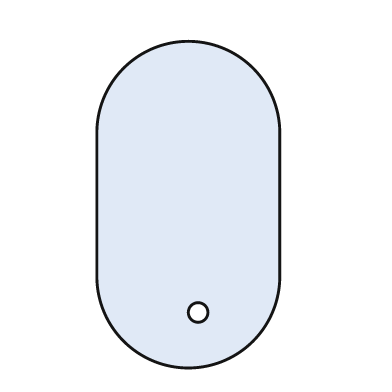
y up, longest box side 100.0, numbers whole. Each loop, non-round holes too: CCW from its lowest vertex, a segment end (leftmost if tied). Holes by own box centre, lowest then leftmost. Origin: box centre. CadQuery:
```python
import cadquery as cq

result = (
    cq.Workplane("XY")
    .moveTo(-28.0, -22.0)
    .threePointArc((0.0, -50.0), (28.0, -22.0))
    .lineTo(28.0, 22.0)
    .threePointArc((0.0, 50.0), (-28.0, 22.0))
    .close()
    .moveTo(3.0, -33.0)
    .circle(3.0)
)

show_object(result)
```